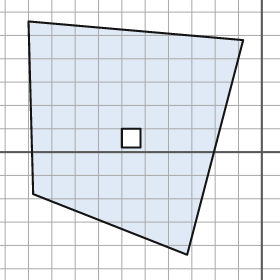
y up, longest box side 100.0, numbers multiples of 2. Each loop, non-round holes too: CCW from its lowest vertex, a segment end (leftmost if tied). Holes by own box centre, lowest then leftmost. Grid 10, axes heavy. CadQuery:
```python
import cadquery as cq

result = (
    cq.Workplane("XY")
    .moveTo(-32.0, -44.0)
    .lineTo(-8.0, 48.0)
    .lineTo(-100.0, 56.0)
    .lineTo(-98.0, -18.0)
    .close()
    .moveTo(-60.0, 2.0)
    .lineTo(-52.0, 2.0)
    .lineTo(-52.0, 10.0)
    .lineTo(-60.0, 10.0)
    .close()
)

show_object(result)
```